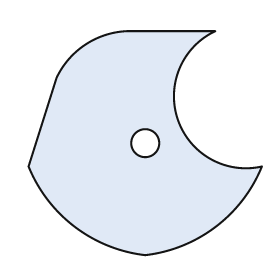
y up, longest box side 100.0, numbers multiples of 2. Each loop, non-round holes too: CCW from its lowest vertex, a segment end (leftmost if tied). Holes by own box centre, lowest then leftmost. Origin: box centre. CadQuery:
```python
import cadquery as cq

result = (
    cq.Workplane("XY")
    .moveTo(0.0, -48.0)
    .threePointArc((30.0, -36.0), (50.0, -10.0))
    .threePointArc((14.0, 10.0), (30.0, 48.0))
    .lineTo(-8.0, 48.0)
    .threePointArc((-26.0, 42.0), (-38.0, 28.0))
    .lineTo(-50.0, -10.0)
    .threePointArc((-30.0, -36.0), (0.0, -48.0))
    .close()
    .moveTo(0.0, 0.0)
    .circle(6.0)
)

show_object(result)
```